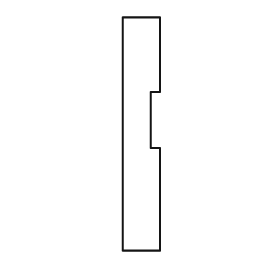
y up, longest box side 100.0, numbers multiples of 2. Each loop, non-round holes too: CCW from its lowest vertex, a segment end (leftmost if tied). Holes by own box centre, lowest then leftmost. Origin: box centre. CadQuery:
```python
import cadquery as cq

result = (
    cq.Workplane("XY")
    .moveTo(-8.0, -50.0)
    .lineTo(8.0, -50.0)
    .lineTo(8.0, -6.0)
    .lineTo(4.0, -6.0)
    .lineTo(4.0, 18.0)
    .lineTo(8.0, 18.0)
    .lineTo(8.0, 50.0)
    .lineTo(-8.0, 50.0)
    .close()
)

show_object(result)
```